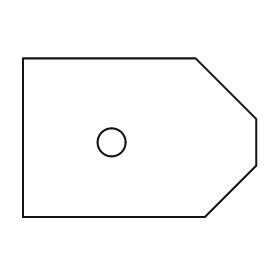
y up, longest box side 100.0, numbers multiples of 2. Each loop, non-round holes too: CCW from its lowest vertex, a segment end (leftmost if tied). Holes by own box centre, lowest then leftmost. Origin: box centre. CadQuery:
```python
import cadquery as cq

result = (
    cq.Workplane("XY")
    .moveTo(-50.0, -34.0)
    .lineTo(28.0, -34.0)
    .lineTo(50.0, -12.0)
    .lineTo(50.0, 8.0)
    .lineTo(24.0, 34.0)
    .lineTo(-50.0, 34.0)
    .close()
    .moveTo(-12.0, -2.0)
    .circle(6.0)
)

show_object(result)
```